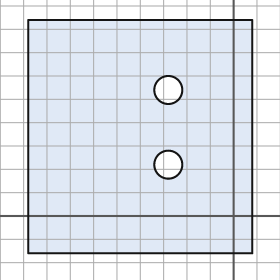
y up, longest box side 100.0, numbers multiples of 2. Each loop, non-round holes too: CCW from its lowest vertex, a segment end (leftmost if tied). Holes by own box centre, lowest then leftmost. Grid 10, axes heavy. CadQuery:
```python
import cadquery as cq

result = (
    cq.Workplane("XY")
    .moveTo(-88.0, -16.0)
    .lineTo(8.0, -16.0)
    .lineTo(8.0, 84.0)
    .lineTo(-88.0, 84.0)
    .close()
    .moveTo(-28.0, 22.0)
    .circle(6.0)
    .moveTo(-28.0, 54.0)
    .circle(6.0)
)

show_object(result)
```